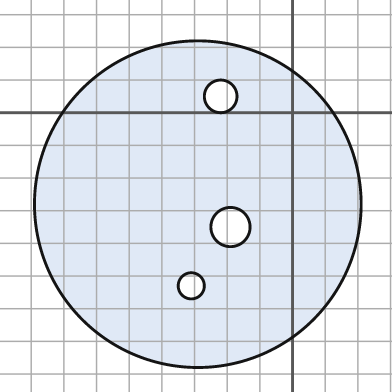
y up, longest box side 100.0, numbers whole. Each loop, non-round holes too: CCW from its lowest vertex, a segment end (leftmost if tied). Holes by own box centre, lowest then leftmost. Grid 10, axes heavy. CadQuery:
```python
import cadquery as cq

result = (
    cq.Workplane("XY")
    .moveTo(-29.0, -28.0)
    .circle(50.0)
    .moveTo(-31.0, -53.0)
    .circle(4.0)
    .moveTo(-19.0, -35.0)
    .circle(6.0)
    .moveTo(-22.0, 5.0)
    .circle(5.0)
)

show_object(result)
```